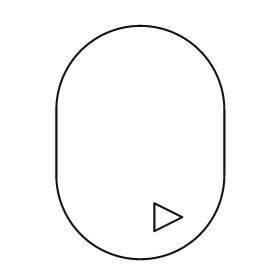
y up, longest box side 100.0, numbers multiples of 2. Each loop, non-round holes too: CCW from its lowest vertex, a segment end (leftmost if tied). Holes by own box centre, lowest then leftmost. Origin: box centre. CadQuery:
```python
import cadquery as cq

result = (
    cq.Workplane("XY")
    .moveTo(-36.0, -14.0)
    .threePointArc((0.0, -50.0), (36.0, -14.0))
    .lineTo(36.0, 14.0)
    .threePointArc((0.0, 50.0), (-36.0, 14.0))
    .close()
    .moveTo(6.0, -38.0)
    .lineTo(18.0, -32.0)
    .lineTo(6.0, -26.0)
    .close()
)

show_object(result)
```